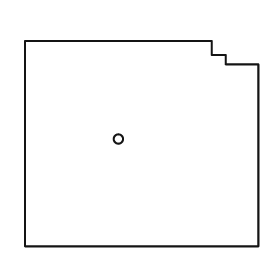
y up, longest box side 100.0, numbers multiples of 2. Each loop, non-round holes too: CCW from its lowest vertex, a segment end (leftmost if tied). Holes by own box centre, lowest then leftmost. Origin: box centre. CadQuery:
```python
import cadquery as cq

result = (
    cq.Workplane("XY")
    .moveTo(-50.0, -44.0)
    .lineTo(50.0, -44.0)
    .lineTo(50.0, 34.0)
    .lineTo(36.0, 34.0)
    .lineTo(36.0, 38.0)
    .lineTo(30.0, 38.0)
    .lineTo(30.0, 44.0)
    .lineTo(-50.0, 44.0)
    .close()
    .moveTo(-10.0, 2.0)
    .circle(2.0)
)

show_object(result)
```